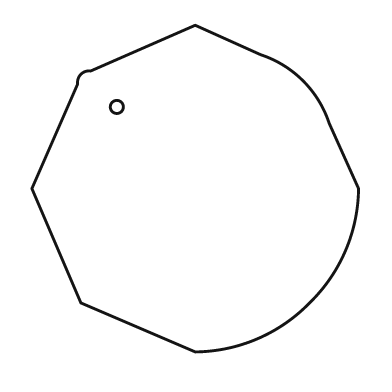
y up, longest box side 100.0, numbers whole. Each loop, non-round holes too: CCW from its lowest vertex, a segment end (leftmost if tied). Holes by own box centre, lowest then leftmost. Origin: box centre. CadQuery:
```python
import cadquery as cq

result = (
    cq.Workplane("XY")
    .moveTo(0.0, -50.0)
    .threePointArc((19.0, -46.0), (35.0, -35.0))
    .threePointArc((46.0, -19.0), (50.0, 0.0))
    .lineTo(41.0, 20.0)
    .threePointArc((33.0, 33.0), (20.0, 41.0))
    .lineTo(0.0, 50.0)
    .lineTo(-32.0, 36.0)
    .threePointArc((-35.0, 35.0), (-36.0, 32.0))
    .lineTo(-50.0, 0.0)
    .lineTo(-35.0, -35.0)
    .close()
    .moveTo(-24.0, 25.0)
    .circle(2.0)
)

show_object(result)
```